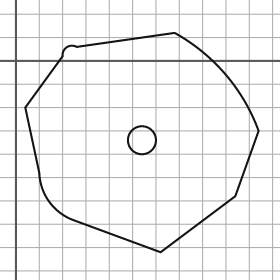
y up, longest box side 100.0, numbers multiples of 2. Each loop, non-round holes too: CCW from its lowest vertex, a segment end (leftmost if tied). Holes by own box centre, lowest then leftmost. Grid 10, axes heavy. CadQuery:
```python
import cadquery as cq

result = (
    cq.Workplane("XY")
    .moveTo(62.0, -82.0)
    .lineTo(94.0, -58.0)
    .lineTo(104.0, -30.0)
    .threePointArc((90.0, -6.0), (68.0, 12.0))
    .lineTo(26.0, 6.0)
    .threePointArc((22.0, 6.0), (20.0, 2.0))
    .lineTo(4.0, -20.0)
    .lineTo(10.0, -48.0)
    .threePointArc((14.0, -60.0), (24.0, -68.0))
    .close()
    .moveTo(54.0, -34.0)
    .circle(6.0)
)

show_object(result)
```